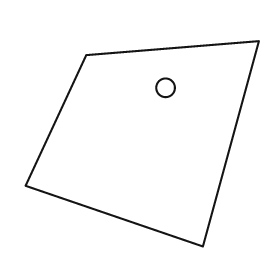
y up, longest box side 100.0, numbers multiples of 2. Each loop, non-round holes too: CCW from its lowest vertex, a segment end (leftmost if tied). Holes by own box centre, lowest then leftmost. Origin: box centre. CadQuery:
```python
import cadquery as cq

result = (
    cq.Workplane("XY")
    .moveTo(26.0, -44.0)
    .lineTo(50.0, 44.0)
    .lineTo(-24.0, 38.0)
    .lineTo(-50.0, -18.0)
    .close()
    .moveTo(10.0, 24.0)
    .circle(4.0)
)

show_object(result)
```